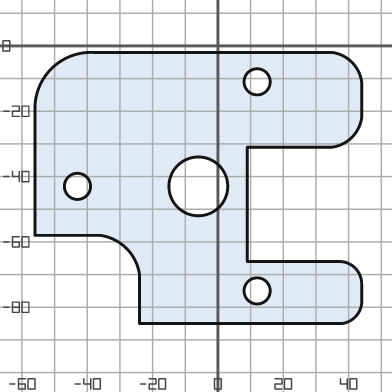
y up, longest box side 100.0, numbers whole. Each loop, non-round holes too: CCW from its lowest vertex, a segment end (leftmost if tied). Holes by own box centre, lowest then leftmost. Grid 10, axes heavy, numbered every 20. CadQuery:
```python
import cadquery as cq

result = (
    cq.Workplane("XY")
    .moveTo(-24.0, -85.0)
    .lineTo(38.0, -85.0)
    .threePointArc((42.0, -83.0), (44.0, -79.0))
    .lineTo(44.0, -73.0)
    .threePointArc((42.0, -68.0), (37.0, -66.0))
    .lineTo(9.0, -66.0)
    .lineTo(9.0, -31.0)
    .lineTo(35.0, -31.0)
    .threePointArc((41.0, -28.0), (44.0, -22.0))
    .lineTo(44.0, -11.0)
    .threePointArc((41.0, -5.0), (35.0, -2.0))
    .lineTo(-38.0, -2.0)
    .threePointArc((-51.0, -7.0), (-56.0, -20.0))
    .lineTo(-56.0, -58.0)
    .lineTo(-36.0, -58.0)
    .threePointArc((-28.0, -62.0), (-24.0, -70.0))
    .close()
    .moveTo(12.0, -75.0)
    .circle(4.0)
    .moveTo(-43.0, -43.0)
    .circle(4.0)
    .moveTo(-6.0, -43.0)
    .circle(9.0)
    .moveTo(12.0, -11.0)
    .circle(4.0)
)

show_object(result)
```